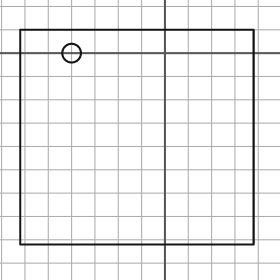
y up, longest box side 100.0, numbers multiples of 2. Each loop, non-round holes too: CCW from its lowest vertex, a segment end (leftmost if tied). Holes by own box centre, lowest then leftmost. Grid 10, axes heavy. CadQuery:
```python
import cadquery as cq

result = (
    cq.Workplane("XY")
    .moveTo(-62.0, -82.0)
    .lineTo(38.0, -82.0)
    .lineTo(38.0, 10.0)
    .lineTo(-62.0, 10.0)
    .close()
    .moveTo(-40.0, 0.0)
    .circle(4.0)
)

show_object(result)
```